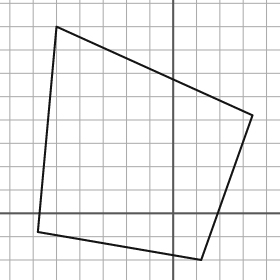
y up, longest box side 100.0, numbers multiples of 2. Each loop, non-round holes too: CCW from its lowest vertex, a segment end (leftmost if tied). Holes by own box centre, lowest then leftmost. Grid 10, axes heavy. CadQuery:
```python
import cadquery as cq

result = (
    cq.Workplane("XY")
    .moveTo(12.0, -20.0)
    .lineTo(34.0, 42.0)
    .lineTo(-50.0, 80.0)
    .lineTo(-58.0, -8.0)
    .close()
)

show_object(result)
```